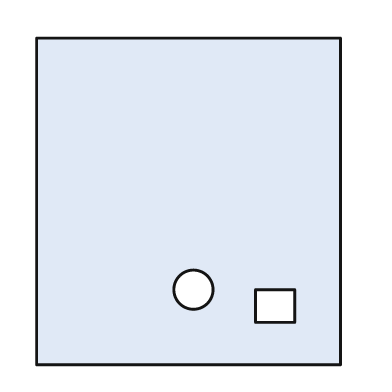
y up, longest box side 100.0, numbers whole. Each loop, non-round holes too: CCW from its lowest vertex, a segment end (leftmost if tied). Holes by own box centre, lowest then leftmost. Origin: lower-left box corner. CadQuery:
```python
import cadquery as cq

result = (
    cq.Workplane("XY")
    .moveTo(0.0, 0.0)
    .lineTo(93.0, 0.0)
    .lineTo(93.0, 100.0)
    .lineTo(0.0, 100.0)
    .close()
    .moveTo(67.0, 13.0)
    .lineTo(79.0, 13.0)
    .lineTo(79.0, 23.0)
    .lineTo(67.0, 23.0)
    .close()
    .moveTo(48.0, 23.0)
    .circle(6.0)
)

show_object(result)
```